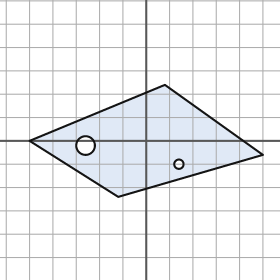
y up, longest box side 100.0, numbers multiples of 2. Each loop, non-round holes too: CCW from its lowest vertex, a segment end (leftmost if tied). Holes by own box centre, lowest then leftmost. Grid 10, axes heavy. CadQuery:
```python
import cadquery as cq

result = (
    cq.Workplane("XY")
    .moveTo(-12.0, -24.0)
    .lineTo(50.0, -6.0)
    .lineTo(8.0, 24.0)
    .lineTo(-50.0, 0.0)
    .close()
    .moveTo(14.0, -10.0)
    .circle(2.0)
    .moveTo(-26.0, -2.0)
    .circle(4.0)
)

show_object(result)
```